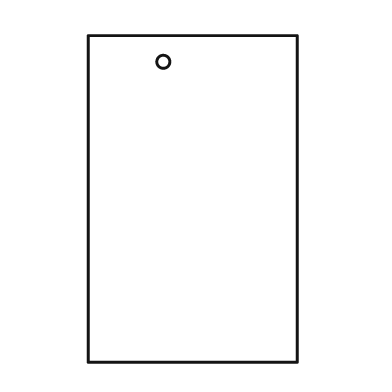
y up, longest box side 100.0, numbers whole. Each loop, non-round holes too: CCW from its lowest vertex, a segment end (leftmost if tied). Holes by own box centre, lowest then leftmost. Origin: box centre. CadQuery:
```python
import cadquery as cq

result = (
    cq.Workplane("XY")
    .moveTo(-32.0, -50.0)
    .lineTo(32.0, -50.0)
    .lineTo(32.0, 50.0)
    .lineTo(-32.0, 50.0)
    .close()
    .moveTo(-9.0, 42.0)
    .circle(2.0)
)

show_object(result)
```